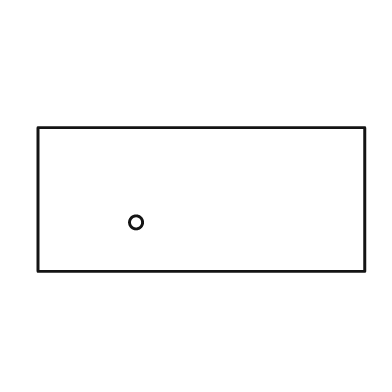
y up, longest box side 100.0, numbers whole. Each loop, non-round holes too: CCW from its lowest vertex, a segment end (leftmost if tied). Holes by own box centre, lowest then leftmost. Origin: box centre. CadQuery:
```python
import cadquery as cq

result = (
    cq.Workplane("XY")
    .moveTo(-50.0, -22.0)
    .lineTo(50.0, -22.0)
    .lineTo(50.0, 22.0)
    .lineTo(-50.0, 22.0)
    .close()
    .moveTo(-20.0, -7.0)
    .circle(2.0)
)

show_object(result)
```